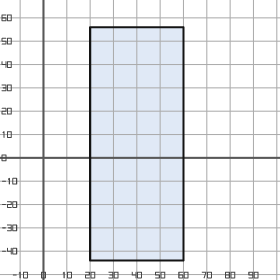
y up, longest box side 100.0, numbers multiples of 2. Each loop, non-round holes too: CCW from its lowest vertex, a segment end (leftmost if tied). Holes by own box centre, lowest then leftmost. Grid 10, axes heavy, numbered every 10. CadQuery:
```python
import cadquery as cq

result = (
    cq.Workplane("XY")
    .moveTo(20.0, -44.0)
    .lineTo(60.0, -44.0)
    .lineTo(60.0, 56.0)
    .lineTo(20.0, 56.0)
    .close()
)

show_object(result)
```